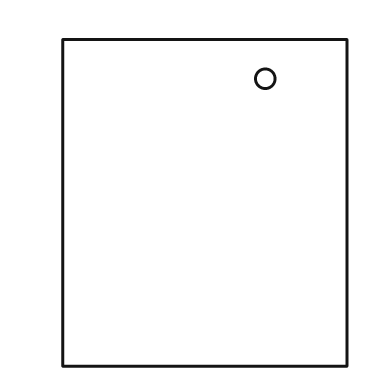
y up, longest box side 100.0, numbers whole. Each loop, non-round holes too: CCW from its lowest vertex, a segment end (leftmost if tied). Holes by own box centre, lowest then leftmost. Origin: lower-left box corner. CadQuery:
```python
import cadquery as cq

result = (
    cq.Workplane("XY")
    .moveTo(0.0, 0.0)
    .lineTo(87.0, 0.0)
    .lineTo(87.0, 100.0)
    .lineTo(0.0, 100.0)
    .close()
    .moveTo(62.0, 88.0)
    .circle(3.0)
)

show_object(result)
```